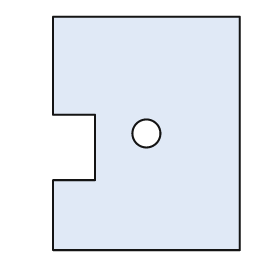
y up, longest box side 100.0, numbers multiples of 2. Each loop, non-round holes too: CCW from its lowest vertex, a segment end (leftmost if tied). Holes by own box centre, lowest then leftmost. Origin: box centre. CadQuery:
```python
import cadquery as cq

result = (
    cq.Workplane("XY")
    .moveTo(-40.0, -50.0)
    .lineTo(40.0, -50.0)
    .lineTo(40.0, 50.0)
    .lineTo(-40.0, 50.0)
    .lineTo(-40.0, 8.0)
    .lineTo(-22.0, 8.0)
    .lineTo(-22.0, -20.0)
    .lineTo(-40.0, -20.0)
    .close()
    .moveTo(0.0, 0.0)
    .circle(6.0)
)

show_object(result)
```